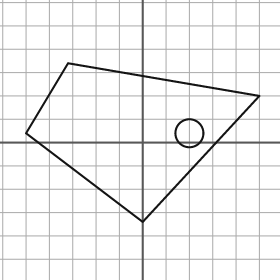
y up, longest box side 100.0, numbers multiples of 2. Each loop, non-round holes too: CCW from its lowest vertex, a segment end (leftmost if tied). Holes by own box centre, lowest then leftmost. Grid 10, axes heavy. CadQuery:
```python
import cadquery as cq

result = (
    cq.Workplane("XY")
    .moveTo(0.0, -34.0)
    .lineTo(50.0, 20.0)
    .lineTo(-32.0, 34.0)
    .lineTo(-50.0, 4.0)
    .close()
    .moveTo(20.0, 4.0)
    .circle(6.0)
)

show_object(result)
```